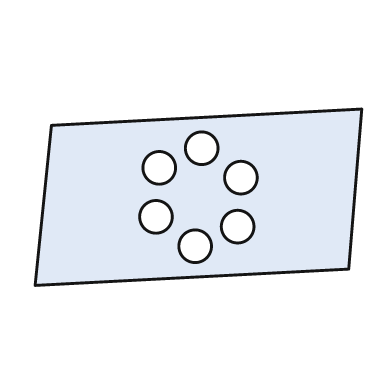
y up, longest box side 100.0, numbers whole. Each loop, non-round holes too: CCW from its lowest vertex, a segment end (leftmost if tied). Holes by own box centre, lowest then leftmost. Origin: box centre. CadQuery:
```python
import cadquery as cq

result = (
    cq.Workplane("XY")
    .moveTo(-50.0, -27.0)
    .lineTo(46.0, -22.0)
    .lineTo(50.0, 27.0)
    .lineTo(-45.0, 22.0)
    .close()
    .moveTo(-1.0, -15.0)
    .circle(5.0)
    .moveTo(12.0, -9.0)
    .circle(5.0)
    .moveTo(-13.0, -6.0)
    .circle(5.0)
    .moveTo(13.0, 6.0)
    .circle(5.0)
    .moveTo(-12.0, 9.0)
    .circle(5.0)
    .moveTo(1.0, 15.0)
    .circle(5.0)
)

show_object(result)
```